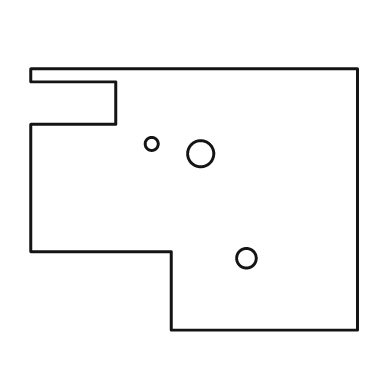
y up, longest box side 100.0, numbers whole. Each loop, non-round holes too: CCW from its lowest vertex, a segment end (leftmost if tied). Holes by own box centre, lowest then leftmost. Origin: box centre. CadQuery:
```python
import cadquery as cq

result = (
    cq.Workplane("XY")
    .moveTo(-7.0, -40.0)
    .lineTo(50.0, -40.0)
    .lineTo(50.0, 40.0)
    .lineTo(-50.0, 40.0)
    .lineTo(-50.0, 36.0)
    .lineTo(-24.0, 36.0)
    .lineTo(-24.0, 23.0)
    .lineTo(-50.0, 23.0)
    .lineTo(-50.0, -16.0)
    .lineTo(-7.0, -16.0)
    .close()
    .moveTo(16.0, -18.0)
    .circle(3.0)
    .moveTo(2.0, 14.0)
    .circle(4.0)
    .moveTo(-13.0, 17.0)
    .circle(2.0)
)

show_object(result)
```